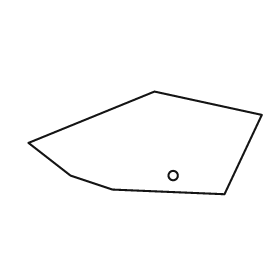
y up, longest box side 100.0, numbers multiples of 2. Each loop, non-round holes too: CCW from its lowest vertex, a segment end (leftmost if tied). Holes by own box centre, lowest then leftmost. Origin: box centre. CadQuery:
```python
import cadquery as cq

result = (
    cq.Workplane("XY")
    .moveTo(34.0, -22.0)
    .lineTo(50.0, 12.0)
    .lineTo(4.0, 22.0)
    .lineTo(-50.0, 0.0)
    .lineTo(-32.0, -14.0)
    .lineTo(-14.0, -20.0)
    .close()
    .moveTo(12.0, -14.0)
    .circle(2.0)
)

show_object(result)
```